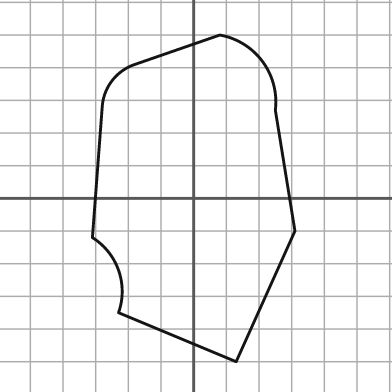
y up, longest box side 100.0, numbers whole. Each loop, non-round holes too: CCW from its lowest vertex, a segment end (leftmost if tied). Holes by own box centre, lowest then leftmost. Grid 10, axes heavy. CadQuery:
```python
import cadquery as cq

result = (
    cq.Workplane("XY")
    .moveTo(13.0, -50.0)
    .lineTo(31.0, -10.0)
    .lineTo(25.0, 27.0)
    .threePointArc((21.0, 42.0), (8.0, 50.0))
    .lineTo(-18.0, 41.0)
    .threePointArc((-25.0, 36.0), (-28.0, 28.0))
    .lineTo(-31.0, -12.0)
    .threePointArc((-23.0, -22.0), (-23.0, -35.0))
    .close()
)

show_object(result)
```